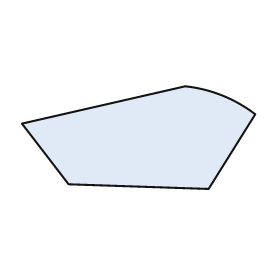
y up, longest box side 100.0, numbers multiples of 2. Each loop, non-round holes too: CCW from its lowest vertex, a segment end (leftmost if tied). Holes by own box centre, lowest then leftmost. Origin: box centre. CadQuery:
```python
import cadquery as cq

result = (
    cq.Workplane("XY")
    .moveTo(30.0, -22.0)
    .lineTo(50.0, 10.0)
    .threePointArc((36.0, 18.0), (20.0, 22.0))
    .lineTo(-50.0, 6.0)
    .lineTo(-30.0, -20.0)
    .close()
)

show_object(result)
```